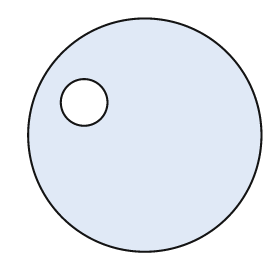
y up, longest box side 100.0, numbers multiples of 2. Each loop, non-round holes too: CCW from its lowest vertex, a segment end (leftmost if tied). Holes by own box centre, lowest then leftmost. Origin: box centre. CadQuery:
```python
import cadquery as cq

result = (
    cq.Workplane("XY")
    .moveTo(0.0, 0.0)
    .circle(50.0)
    .moveTo(-26.0, 14.0)
    .circle(10.0)
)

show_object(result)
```